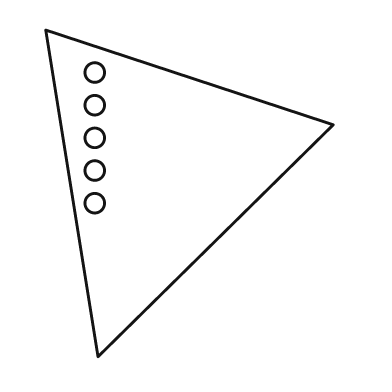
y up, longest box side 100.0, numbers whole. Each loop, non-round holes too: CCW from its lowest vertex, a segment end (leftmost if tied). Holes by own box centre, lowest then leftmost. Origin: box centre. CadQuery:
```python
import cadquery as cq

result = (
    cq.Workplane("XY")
    .moveTo(-28.0, -50.0)
    .lineTo(44.0, 21.0)
    .lineTo(-44.0, 50.0)
    .close()
    .moveTo(-29.0, -3.0)
    .circle(3.0)
    .moveTo(-29.0, 7.0)
    .circle(3.0)
    .moveTo(-29.0, 17.0)
    .circle(3.0)
    .moveTo(-29.0, 27.0)
    .circle(3.0)
    .moveTo(-29.0, 37.0)
    .circle(3.0)
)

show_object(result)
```